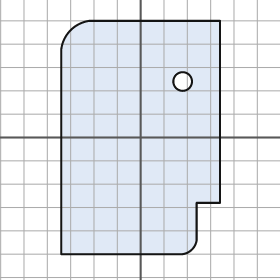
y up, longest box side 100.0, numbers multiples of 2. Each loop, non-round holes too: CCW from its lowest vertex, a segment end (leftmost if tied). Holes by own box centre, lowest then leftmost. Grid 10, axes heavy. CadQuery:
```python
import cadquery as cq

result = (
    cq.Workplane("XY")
    .moveTo(-34.0, -50.0)
    .lineTo(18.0, -50.0)
    .threePointArc((22.0, -48.0), (24.0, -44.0))
    .lineTo(24.0, -28.0)
    .lineTo(34.0, -28.0)
    .lineTo(34.0, 50.0)
    .lineTo(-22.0, 50.0)
    .threePointArc((-30.0, 46.0), (-34.0, 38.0))
    .close()
    .moveTo(18.0, 24.0)
    .circle(4.0)
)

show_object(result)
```